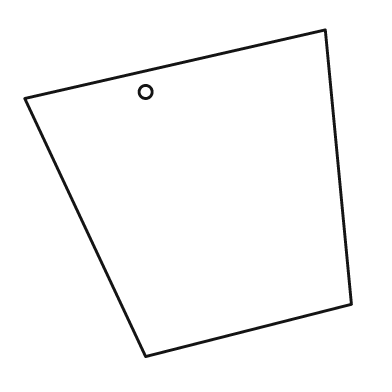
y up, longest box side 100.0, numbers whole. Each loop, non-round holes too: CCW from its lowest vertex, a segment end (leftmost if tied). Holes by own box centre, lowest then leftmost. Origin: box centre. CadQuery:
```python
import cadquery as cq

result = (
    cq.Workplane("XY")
    .moveTo(-13.0, -50.0)
    .lineTo(50.0, -34.0)
    .lineTo(42.0, 50.0)
    .lineTo(-50.0, 29.0)
    .close()
    .moveTo(-13.0, 31.0)
    .circle(2.0)
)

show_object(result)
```